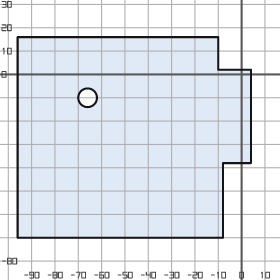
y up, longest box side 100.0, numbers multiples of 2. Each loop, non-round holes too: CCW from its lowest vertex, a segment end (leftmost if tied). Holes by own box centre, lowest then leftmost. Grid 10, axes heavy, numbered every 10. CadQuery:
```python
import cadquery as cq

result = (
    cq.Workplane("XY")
    .moveTo(-96.0, -70.0)
    .lineTo(-8.0, -70.0)
    .lineTo(-8.0, -38.0)
    .lineTo(4.0, -38.0)
    .lineTo(4.0, 2.0)
    .lineTo(-10.0, 2.0)
    .lineTo(-10.0, 16.0)
    .lineTo(-96.0, 16.0)
    .close()
    .moveTo(-66.0, -10.0)
    .circle(4.0)
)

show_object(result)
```